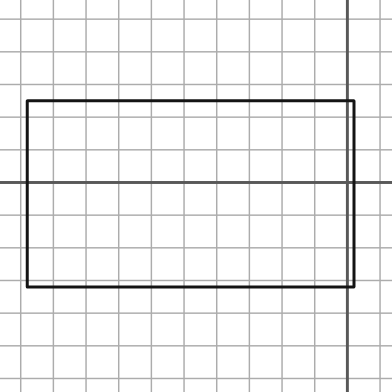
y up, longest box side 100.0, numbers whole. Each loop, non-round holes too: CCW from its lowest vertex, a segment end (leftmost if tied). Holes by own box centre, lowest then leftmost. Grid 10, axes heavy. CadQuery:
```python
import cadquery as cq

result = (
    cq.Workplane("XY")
    .moveTo(-98.0, -32.0)
    .lineTo(2.0, -32.0)
    .lineTo(2.0, 25.0)
    .lineTo(-98.0, 25.0)
    .close()
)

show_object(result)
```